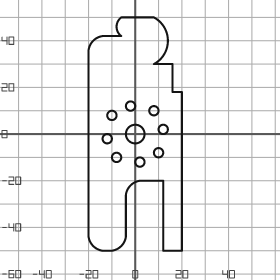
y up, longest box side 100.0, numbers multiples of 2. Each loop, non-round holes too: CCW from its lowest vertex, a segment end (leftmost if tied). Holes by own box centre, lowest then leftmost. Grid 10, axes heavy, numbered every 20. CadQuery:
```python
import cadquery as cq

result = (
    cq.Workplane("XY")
    .moveTo(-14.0, -50.0)
    .lineTo(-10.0, -50.0)
    .threePointArc((-6.0, -48.0), (-4.0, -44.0))
    .lineTo(-4.0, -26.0)
    .threePointArc((-2.0, -22.0), (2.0, -20.0))
    .lineTo(12.0, -20.0)
    .lineTo(12.0, -50.0)
    .lineTo(20.0, -50.0)
    .lineTo(20.0, 18.0)
    .lineTo(16.0, 18.0)
    .lineTo(16.0, 30.0)
    .lineTo(8.0, 30.0)
    .threePointArc((14.0, 40.0), (8.0, 50.0))
    .lineTo(-6.0, 50.0)
    .threePointArc((-8.0, 46.0), (-6.0, 42.0))
    .lineTo(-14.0, 42.0)
    .threePointArc((-18.0, 40.0), (-20.0, 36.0))
    .lineTo(-20.0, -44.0)
    .threePointArc((-18.0, -48.0), (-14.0, -50.0))
    .close()
    .moveTo(2.0, -12.0)
    .circle(2.0)
    .moveTo(-8.0, -10.0)
    .circle(2.0)
    .moveTo(10.0, -8.0)
    .circle(2.0)
    .moveTo(-12.0, -2.0)
    .circle(2.0)
    .moveTo(0.0, 0.0)
    .circle(4.0)
    .moveTo(12.0, 2.0)
    .circle(2.0)
    .moveTo(-10.0, 8.0)
    .circle(2.0)
    .moveTo(8.0, 10.0)
    .circle(2.0)
    .moveTo(-2.0, 12.0)
    .circle(2.0)
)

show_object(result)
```